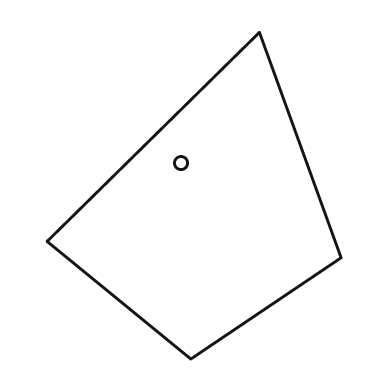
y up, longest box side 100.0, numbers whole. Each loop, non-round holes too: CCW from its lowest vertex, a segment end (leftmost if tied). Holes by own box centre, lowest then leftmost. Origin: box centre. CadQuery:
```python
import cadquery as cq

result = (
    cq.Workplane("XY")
    .moveTo(-1.0, -50.0)
    .lineTo(45.0, -19.0)
    .lineTo(20.0, 50.0)
    .lineTo(-45.0, -14.0)
    .close()
    .moveTo(-4.0, 10.0)
    .circle(2.0)
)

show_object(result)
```